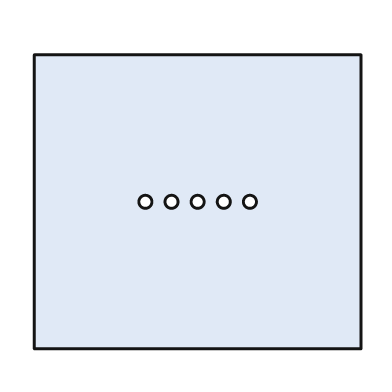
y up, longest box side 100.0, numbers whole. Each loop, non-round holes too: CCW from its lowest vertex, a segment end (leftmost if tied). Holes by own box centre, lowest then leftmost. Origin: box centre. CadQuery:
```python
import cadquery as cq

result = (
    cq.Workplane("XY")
    .moveTo(-50.0, -45.0)
    .lineTo(50.0, -45.0)
    .lineTo(50.0, 45.0)
    .lineTo(-50.0, 45.0)
    .close()
    .moveTo(-16.0, 0.0)
    .circle(2.0)
    .moveTo(-8.0, 0.0)
    .circle(2.0)
    .moveTo(0.0, 0.0)
    .circle(2.0)
    .moveTo(8.0, 0.0)
    .circle(2.0)
    .moveTo(16.0, 0.0)
    .circle(2.0)
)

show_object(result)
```